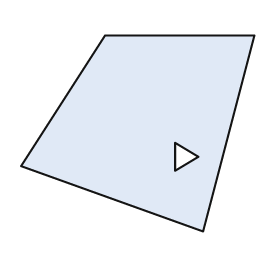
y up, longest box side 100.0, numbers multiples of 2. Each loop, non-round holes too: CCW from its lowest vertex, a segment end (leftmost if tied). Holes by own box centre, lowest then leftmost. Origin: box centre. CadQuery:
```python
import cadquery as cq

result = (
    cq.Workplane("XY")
    .moveTo(28.0, -42.0)
    .lineTo(50.0, 42.0)
    .lineTo(-14.0, 42.0)
    .lineTo(-50.0, -14.0)
    .close()
    .moveTo(16.0, -16.0)
    .lineTo(26.0, -10.0)
    .lineTo(16.0, -4.0)
    .close()
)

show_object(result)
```